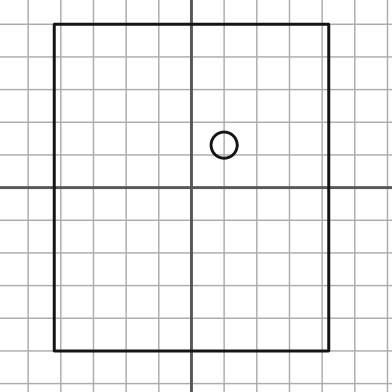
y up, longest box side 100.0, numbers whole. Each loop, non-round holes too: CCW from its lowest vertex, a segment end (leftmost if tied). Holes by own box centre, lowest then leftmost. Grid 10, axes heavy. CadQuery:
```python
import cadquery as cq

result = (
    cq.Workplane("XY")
    .moveTo(-42.0, -50.0)
    .lineTo(42.0, -50.0)
    .lineTo(42.0, 50.0)
    .lineTo(-42.0, 50.0)
    .close()
    .moveTo(10.0, 13.0)
    .circle(4.0)
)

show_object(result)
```